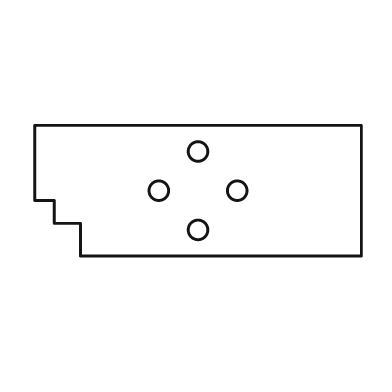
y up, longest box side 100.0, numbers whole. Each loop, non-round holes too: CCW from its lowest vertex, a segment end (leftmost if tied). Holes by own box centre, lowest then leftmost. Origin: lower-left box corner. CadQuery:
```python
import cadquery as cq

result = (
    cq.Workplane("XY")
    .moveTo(14.0, 0.0)
    .lineTo(100.0, 0.0)
    .lineTo(100.0, 40.0)
    .lineTo(0.0, 40.0)
    .lineTo(0.0, 17.0)
    .lineTo(6.0, 17.0)
    .lineTo(6.0, 10.0)
    .lineTo(14.0, 10.0)
    .close()
    .moveTo(50.0, 8.0)
    .circle(3.0)
    .moveTo(38.0, 20.0)
    .circle(3.0)
    .moveTo(62.0, 20.0)
    .circle(3.0)
    .moveTo(50.0, 32.0)
    .circle(3.0)
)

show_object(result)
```